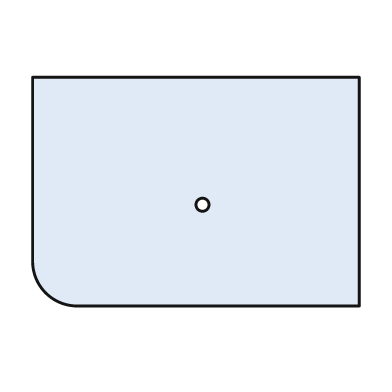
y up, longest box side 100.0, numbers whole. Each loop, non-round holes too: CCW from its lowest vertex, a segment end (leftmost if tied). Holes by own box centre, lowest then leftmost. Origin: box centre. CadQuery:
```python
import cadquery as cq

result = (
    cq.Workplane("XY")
    .moveTo(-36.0, -35.0)
    .lineTo(50.0, -35.0)
    .lineTo(50.0, 35.0)
    .lineTo(-50.0, 35.0)
    .lineTo(-50.0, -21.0)
    .threePointArc((-46.0, -31.0), (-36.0, -35.0))
    .close()
    .moveTo(2.0, -4.0)
    .circle(2.0)
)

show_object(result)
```